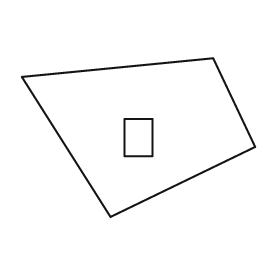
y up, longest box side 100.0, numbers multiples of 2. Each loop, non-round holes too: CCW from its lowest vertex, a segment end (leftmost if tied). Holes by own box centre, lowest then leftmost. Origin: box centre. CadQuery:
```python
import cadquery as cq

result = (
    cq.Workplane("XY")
    .moveTo(-12.0, -34.0)
    .lineTo(50.0, -4.0)
    .lineTo(32.0, 34.0)
    .lineTo(-50.0, 26.0)
    .close()
    .moveTo(-6.0, -8.0)
    .lineTo(6.0, -8.0)
    .lineTo(6.0, 8.0)
    .lineTo(-6.0, 8.0)
    .close()
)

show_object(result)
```